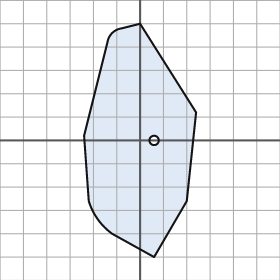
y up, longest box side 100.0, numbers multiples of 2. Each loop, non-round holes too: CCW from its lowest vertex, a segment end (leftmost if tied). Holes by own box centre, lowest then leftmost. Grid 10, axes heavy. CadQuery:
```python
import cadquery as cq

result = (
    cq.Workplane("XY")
    .moveTo(6.0, -50.0)
    .lineTo(20.0, -26.0)
    .lineTo(24.0, 12.0)
    .lineTo(0.0, 50.0)
    .lineTo(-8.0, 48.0)
    .threePointArc((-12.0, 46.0), (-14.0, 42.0))
    .lineTo(-24.0, 2.0)
    .lineTo(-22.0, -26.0)
    .threePointArc((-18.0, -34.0), (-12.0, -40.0))
    .close()
    .moveTo(6.0, 0.0)
    .circle(2.0)
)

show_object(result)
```